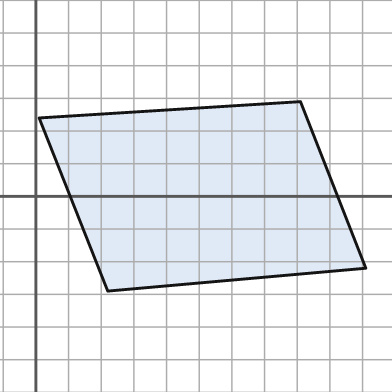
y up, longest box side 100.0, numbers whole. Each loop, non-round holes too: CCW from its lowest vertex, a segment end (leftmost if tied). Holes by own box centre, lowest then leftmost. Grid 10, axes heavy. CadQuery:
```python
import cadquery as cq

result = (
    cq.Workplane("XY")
    .moveTo(22.0, -29.0)
    .lineTo(101.0, -22.0)
    .lineTo(81.0, 29.0)
    .lineTo(1.0, 24.0)
    .close()
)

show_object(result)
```